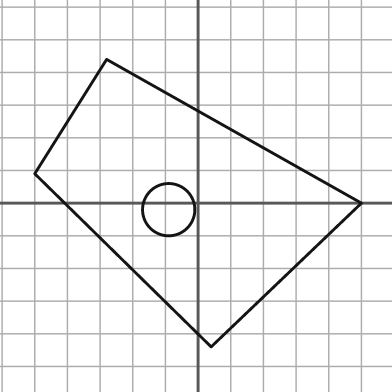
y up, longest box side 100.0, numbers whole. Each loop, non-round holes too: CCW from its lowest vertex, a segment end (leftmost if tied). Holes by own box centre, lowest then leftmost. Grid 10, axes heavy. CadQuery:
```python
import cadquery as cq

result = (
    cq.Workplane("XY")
    .moveTo(4.0, -44.0)
    .lineTo(50.0, 0.0)
    .lineTo(-28.0, 44.0)
    .lineTo(-50.0, 9.0)
    .close()
    .moveTo(-9.0, -2.0)
    .circle(8.0)
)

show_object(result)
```